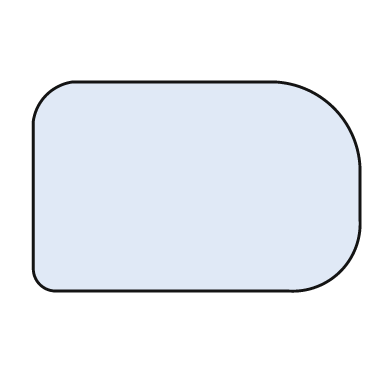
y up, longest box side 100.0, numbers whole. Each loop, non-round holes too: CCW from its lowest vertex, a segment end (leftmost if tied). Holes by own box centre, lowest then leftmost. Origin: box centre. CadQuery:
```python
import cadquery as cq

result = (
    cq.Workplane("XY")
    .moveTo(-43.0, -32.0)
    .lineTo(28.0, -32.0)
    .threePointArc((44.0, -26.0), (50.0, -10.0))
    .lineTo(50.0, 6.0)
    .threePointArc((42.0, 24.0), (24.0, 32.0))
    .lineTo(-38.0, 32.0)
    .threePointArc((-46.0, 28.0), (-50.0, 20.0))
    .lineTo(-50.0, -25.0)
    .threePointArc((-48.0, -30.0), (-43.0, -32.0))
    .close()
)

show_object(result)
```